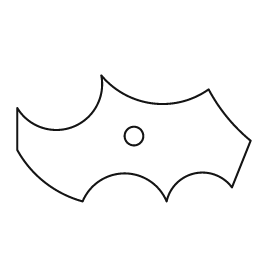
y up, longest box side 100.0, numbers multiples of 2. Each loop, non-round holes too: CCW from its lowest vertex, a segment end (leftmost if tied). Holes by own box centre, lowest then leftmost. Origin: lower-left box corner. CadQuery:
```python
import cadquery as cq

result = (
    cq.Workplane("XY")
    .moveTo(28.0, 0.0)
    .threePointArc((46.0, 12.0), (64.0, 0.0))
    .threePointArc((76.0, 12.0), (92.0, 6.0))
    .lineTo(100.0, 26.0)
    .threePointArc((90.0, 36.0), (82.0, 48.0))
    .threePointArc((58.0, 42.0), (36.0, 54.0))
    .threePointArc((24.0, 32.0), (0.0, 40.0))
    .lineTo(0.0, 22.0)
    .threePointArc((12.0, 8.0), (28.0, 0.0))
    .close()
    .moveTo(50.0, 28.0)
    .circle(4.0)
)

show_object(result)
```